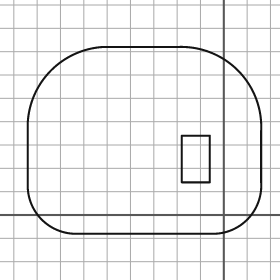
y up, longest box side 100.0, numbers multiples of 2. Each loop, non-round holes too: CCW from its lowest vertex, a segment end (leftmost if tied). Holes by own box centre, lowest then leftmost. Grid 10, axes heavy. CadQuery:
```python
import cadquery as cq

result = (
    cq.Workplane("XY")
    .moveTo(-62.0, -8.0)
    .lineTo(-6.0, -8.0)
    .threePointArc((10.0, -2.0), (16.0, 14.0))
    .lineTo(16.0, 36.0)
    .threePointArc((6.0, 62.0), (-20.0, 72.0))
    .lineTo(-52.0, 72.0)
    .threePointArc((-74.0, 62.0), (-84.0, 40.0))
    .lineTo(-84.0, 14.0)
    .threePointArc((-78.0, -2.0), (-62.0, -8.0))
    .close()
    .moveTo(-18.0, 14.0)
    .lineTo(-6.0, 14.0)
    .lineTo(-6.0, 34.0)
    .lineTo(-18.0, 34.0)
    .close()
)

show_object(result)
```